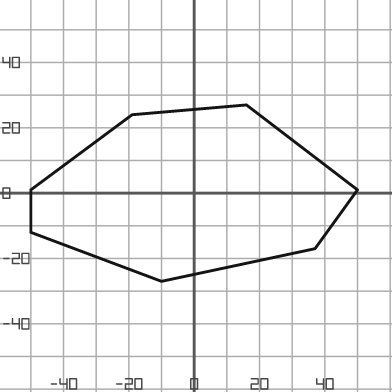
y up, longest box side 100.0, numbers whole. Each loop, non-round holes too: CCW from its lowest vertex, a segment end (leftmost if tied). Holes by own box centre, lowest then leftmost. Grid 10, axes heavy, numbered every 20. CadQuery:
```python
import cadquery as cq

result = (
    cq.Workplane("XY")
    .moveTo(-10.0, -27.0)
    .lineTo(37.0, -17.0)
    .lineTo(50.0, 1.0)
    .lineTo(16.0, 27.0)
    .lineTo(-19.0, 24.0)
    .lineTo(-50.0, 1.0)
    .lineTo(-50.0, -12.0)
    .close()
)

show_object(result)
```